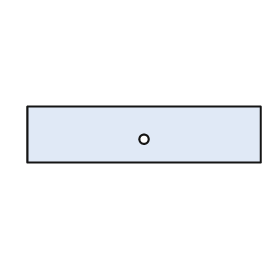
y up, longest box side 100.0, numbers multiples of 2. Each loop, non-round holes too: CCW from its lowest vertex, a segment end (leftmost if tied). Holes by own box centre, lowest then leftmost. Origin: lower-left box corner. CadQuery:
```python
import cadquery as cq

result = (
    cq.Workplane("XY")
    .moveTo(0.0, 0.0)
    .lineTo(100.0, 0.0)
    .lineTo(100.0, 24.0)
    .lineTo(0.0, 24.0)
    .close()
    .moveTo(50.0, 10.0)
    .circle(2.0)
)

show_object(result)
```